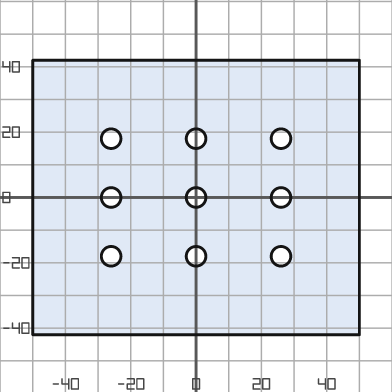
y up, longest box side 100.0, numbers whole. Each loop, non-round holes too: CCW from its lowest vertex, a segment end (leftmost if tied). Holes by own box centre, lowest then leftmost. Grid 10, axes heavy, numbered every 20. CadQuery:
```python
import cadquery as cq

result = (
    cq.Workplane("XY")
    .moveTo(-50.0, -42.0)
    .lineTo(50.0, -42.0)
    .lineTo(50.0, 42.0)
    .lineTo(-50.0, 42.0)
    .close()
    .moveTo(-26.0, -18.0)
    .circle(3.0)
    .moveTo(0.0, -18.0)
    .circle(3.0)
    .moveTo(26.0, -18.0)
    .circle(3.0)
    .moveTo(-26.0, 0.0)
    .circle(3.0)
    .moveTo(0.0, 0.0)
    .circle(3.0)
    .moveTo(26.0, 0.0)
    .circle(3.0)
    .moveTo(-26.0, 18.0)
    .circle(3.0)
    .moveTo(0.0, 18.0)
    .circle(3.0)
    .moveTo(26.0, 18.0)
    .circle(3.0)
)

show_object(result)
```